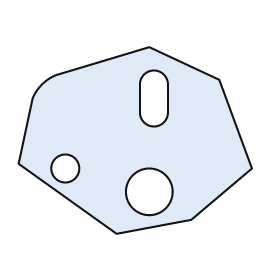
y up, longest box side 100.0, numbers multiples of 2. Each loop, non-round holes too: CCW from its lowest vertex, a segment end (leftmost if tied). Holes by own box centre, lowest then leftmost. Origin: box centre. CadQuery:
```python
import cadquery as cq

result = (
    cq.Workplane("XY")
    .moveTo(-8.0, -40.0)
    .lineTo(24.0, -34.0)
    .lineTo(50.0, -12.0)
    .lineTo(36.0, 26.0)
    .lineTo(6.0, 40.0)
    .lineTo(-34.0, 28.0)
    .threePointArc((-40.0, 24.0), (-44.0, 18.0))
    .lineTo(-50.0, -10.0)
    .close()
    .moveTo(6.0, -22.0)
    .circle(10.0)
    .moveTo(-30.0, -12.0)
    .circle(6.0)
    .moveTo(2.0, 12.0)
    .threePointArc((8.0, 6.0), (14.0, 12.0))
    .lineTo(14.0, 24.0)
    .threePointArc((8.0, 30.0), (2.0, 24.0))
    .close()
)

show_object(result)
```